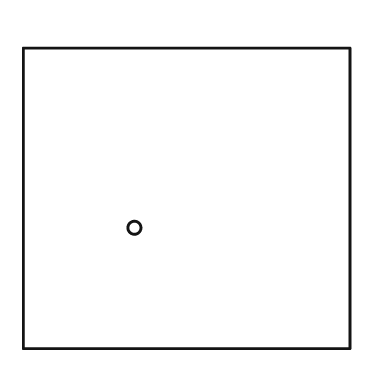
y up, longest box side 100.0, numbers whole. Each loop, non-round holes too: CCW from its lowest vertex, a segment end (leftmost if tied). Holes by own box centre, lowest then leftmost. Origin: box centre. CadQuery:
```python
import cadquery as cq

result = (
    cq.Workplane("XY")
    .moveTo(-50.0, -46.0)
    .lineTo(50.0, -46.0)
    .lineTo(50.0, 46.0)
    .lineTo(-50.0, 46.0)
    .close()
    .moveTo(-16.0, -9.0)
    .circle(2.0)
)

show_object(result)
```